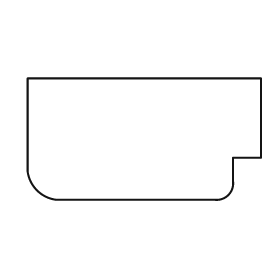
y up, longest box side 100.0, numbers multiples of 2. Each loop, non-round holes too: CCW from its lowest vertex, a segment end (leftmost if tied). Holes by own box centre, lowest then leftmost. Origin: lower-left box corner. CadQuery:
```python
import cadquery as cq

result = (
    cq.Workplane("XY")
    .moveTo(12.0, 0.0)
    .lineTo(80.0, 0.0)
    .threePointArc((86.0, 2.0), (88.0, 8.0))
    .lineTo(88.0, 18.0)
    .lineTo(100.0, 18.0)
    .lineTo(100.0, 52.0)
    .lineTo(0.0, 52.0)
    .lineTo(0.0, 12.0)
    .threePointArc((4.0, 4.0), (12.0, 0.0))
    .close()
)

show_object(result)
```